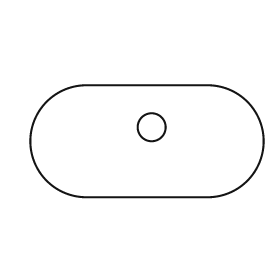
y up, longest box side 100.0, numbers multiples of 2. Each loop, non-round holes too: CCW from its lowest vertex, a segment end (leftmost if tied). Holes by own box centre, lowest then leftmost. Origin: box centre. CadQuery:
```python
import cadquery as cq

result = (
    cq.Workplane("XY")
    .moveTo(-26.0, -24.0)
    .lineTo(26.0, -24.0)
    .threePointArc((50.0, 0.0), (26.0, 24.0))
    .lineTo(-26.0, 24.0)
    .threePointArc((-50.0, 0.0), (-26.0, -24.0))
    .close()
    .moveTo(2.0, 6.0)
    .circle(6.0)
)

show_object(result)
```